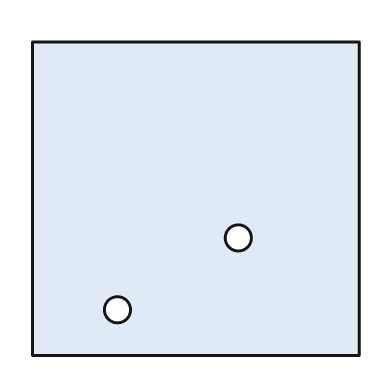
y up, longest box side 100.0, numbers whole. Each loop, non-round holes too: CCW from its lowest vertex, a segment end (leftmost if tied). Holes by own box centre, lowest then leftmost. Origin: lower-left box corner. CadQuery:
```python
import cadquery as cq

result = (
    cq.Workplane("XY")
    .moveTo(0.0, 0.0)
    .lineTo(100.0, 0.0)
    .lineTo(100.0, 96.0)
    .lineTo(0.0, 96.0)
    .close()
    .moveTo(26.0, 14.0)
    .circle(4.0)
    .moveTo(63.0, 36.0)
    .circle(4.0)
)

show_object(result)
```